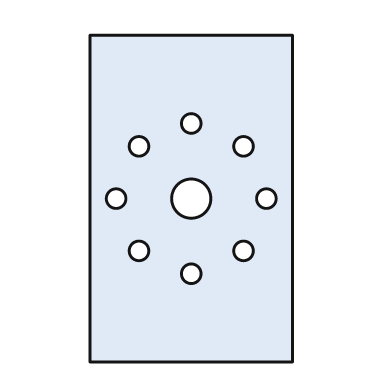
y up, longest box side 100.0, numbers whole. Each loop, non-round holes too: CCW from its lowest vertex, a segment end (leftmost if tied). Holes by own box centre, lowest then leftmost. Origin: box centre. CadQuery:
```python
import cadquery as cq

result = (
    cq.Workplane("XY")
    .moveTo(-31.0, -50.0)
    .lineTo(31.0, -50.0)
    .lineTo(31.0, 50.0)
    .lineTo(-31.0, 50.0)
    .close()
    .moveTo(0.0, -23.0)
    .circle(3.0)
    .moveTo(-16.0, -16.0)
    .circle(3.0)
    .moveTo(16.0, -16.0)
    .circle(3.0)
    .moveTo(-23.0, 0.0)
    .circle(3.0)
    .moveTo(0.0, 0.0)
    .circle(6.0)
    .moveTo(23.0, 0.0)
    .circle(3.0)
    .moveTo(-16.0, 16.0)
    .circle(3.0)
    .moveTo(16.0, 16.0)
    .circle(3.0)
    .moveTo(0.0, 23.0)
    .circle(3.0)
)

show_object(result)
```